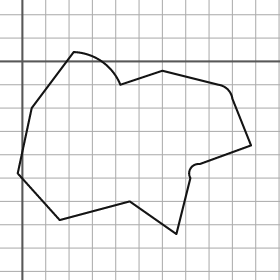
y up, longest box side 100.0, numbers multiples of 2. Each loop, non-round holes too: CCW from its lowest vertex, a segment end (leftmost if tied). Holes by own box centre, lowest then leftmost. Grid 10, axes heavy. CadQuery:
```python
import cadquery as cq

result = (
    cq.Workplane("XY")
    .moveTo(66.0, -74.0)
    .lineTo(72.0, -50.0)
    .threePointArc((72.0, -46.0), (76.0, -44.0))
    .lineTo(98.0, -36.0)
    .lineTo(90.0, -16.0)
    .threePointArc((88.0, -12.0), (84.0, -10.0))
    .lineTo(60.0, -4.0)
    .lineTo(42.0, -10.0)
    .threePointArc((34.0, 0.0), (22.0, 4.0))
    .lineTo(4.0, -20.0)
    .lineTo(-2.0, -48.0)
    .lineTo(16.0, -68.0)
    .lineTo(46.0, -60.0)
    .close()
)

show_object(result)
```